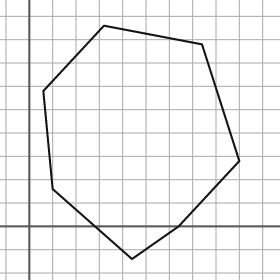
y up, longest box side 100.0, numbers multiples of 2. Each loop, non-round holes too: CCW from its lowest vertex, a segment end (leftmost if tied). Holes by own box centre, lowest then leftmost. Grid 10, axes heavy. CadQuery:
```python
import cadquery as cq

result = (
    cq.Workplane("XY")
    .moveTo(44.0, -14.0)
    .lineTo(64.0, 0.0)
    .lineTo(90.0, 28.0)
    .lineTo(74.0, 78.0)
    .lineTo(32.0, 86.0)
    .lineTo(6.0, 58.0)
    .lineTo(10.0, 16.0)
    .close()
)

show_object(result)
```